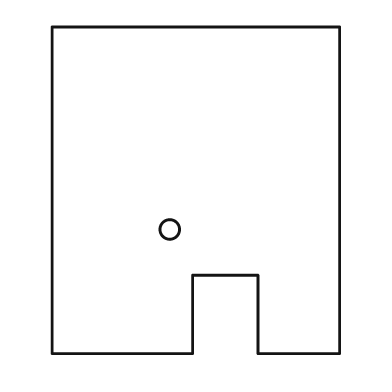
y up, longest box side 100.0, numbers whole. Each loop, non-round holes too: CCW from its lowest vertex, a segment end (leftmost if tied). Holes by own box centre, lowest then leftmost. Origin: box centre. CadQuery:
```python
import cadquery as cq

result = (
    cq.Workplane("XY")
    .moveTo(-44.0, -50.0)
    .lineTo(-1.0, -50.0)
    .lineTo(-1.0, -26.0)
    .lineTo(19.0, -26.0)
    .lineTo(19.0, -50.0)
    .lineTo(44.0, -50.0)
    .lineTo(44.0, 50.0)
    .lineTo(-44.0, 50.0)
    .close()
    .moveTo(-8.0, -12.0)
    .circle(3.0)
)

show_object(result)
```